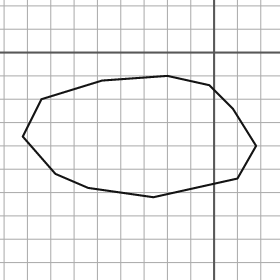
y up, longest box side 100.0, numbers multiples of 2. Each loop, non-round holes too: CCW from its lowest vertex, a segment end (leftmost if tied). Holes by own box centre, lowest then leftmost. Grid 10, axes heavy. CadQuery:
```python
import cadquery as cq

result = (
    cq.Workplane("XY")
    .moveTo(-26.0, -62.0)
    .lineTo(10.0, -54.0)
    .lineTo(18.0, -40.0)
    .lineTo(8.0, -24.0)
    .lineTo(-2.0, -14.0)
    .lineTo(-20.0, -10.0)
    .lineTo(-48.0, -12.0)
    .lineTo(-74.0, -20.0)
    .lineTo(-82.0, -36.0)
    .lineTo(-68.0, -52.0)
    .lineTo(-54.0, -58.0)
    .close()
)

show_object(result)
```